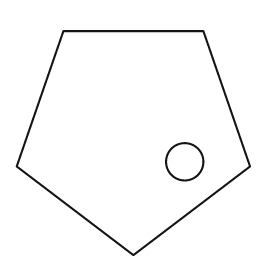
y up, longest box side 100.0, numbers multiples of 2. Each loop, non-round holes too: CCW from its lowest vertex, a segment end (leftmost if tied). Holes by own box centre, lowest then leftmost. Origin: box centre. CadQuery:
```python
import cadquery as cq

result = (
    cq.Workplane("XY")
    .moveTo(0.0, -48.0)
    .lineTo(50.0, -10.0)
    .lineTo(30.0, 48.0)
    .lineTo(-30.0, 48.0)
    .lineTo(-50.0, -10.0)
    .close()
    .moveTo(22.0, -8.0)
    .circle(8.0)
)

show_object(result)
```